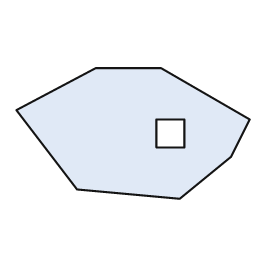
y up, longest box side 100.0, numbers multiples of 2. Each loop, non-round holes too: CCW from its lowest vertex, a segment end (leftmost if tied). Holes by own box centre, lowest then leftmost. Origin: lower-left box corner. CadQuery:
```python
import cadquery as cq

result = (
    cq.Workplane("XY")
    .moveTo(70.0, 0.0)
    .lineTo(92.0, 18.0)
    .lineTo(100.0, 34.0)
    .lineTo(62.0, 56.0)
    .lineTo(34.0, 56.0)
    .lineTo(0.0, 38.0)
    .lineTo(26.0, 4.0)
    .close()
    .moveTo(60.0, 22.0)
    .lineTo(72.0, 22.0)
    .lineTo(72.0, 34.0)
    .lineTo(60.0, 34.0)
    .close()
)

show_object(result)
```